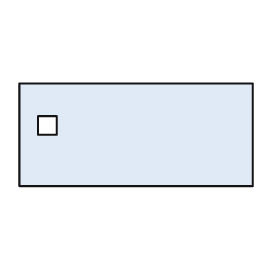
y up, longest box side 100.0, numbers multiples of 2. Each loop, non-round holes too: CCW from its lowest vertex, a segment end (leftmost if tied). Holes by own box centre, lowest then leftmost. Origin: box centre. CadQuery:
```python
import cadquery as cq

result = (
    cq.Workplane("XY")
    .moveTo(-50.0, -22.0)
    .lineTo(50.0, -22.0)
    .lineTo(50.0, 22.0)
    .lineTo(-50.0, 22.0)
    .close()
    .moveTo(-42.0, 0.0)
    .lineTo(-34.0, 0.0)
    .lineTo(-34.0, 8.0)
    .lineTo(-42.0, 8.0)
    .close()
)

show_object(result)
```